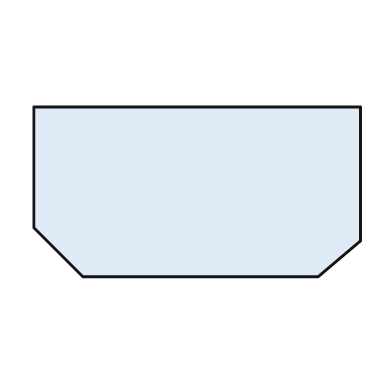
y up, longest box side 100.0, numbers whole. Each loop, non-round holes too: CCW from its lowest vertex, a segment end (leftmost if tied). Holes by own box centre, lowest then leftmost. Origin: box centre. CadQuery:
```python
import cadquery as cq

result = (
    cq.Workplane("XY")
    .moveTo(-35.0, -26.0)
    .lineTo(37.0, -26.0)
    .lineTo(50.0, -15.0)
    .lineTo(50.0, 26.0)
    .lineTo(-50.0, 26.0)
    .lineTo(-50.0, -11.0)
    .close()
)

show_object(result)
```